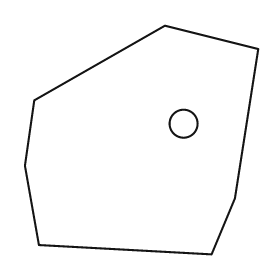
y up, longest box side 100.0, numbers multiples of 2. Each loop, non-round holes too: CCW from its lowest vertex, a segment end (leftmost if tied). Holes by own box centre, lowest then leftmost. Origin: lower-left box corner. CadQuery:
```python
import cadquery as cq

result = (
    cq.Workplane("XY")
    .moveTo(80.0, 0.0)
    .lineTo(90.0, 24.0)
    .lineTo(100.0, 88.0)
    .lineTo(60.0, 98.0)
    .lineTo(4.0, 66.0)
    .lineTo(0.0, 38.0)
    .lineTo(6.0, 4.0)
    .close()
    .moveTo(68.0, 56.0)
    .circle(6.0)
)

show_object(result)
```